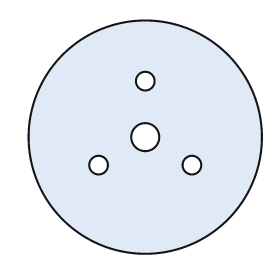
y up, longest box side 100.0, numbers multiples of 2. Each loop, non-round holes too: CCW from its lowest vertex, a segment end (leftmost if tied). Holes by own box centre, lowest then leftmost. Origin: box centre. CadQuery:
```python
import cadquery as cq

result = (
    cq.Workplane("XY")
    .moveTo(0.0, 0.0)
    .circle(50.0)
    .moveTo(-20.0, -12.0)
    .circle(4.0)
    .moveTo(20.0, -12.0)
    .circle(4.0)
    .moveTo(0.0, 0.0)
    .circle(6.0)
    .moveTo(0.0, 24.0)
    .circle(4.0)
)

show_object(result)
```